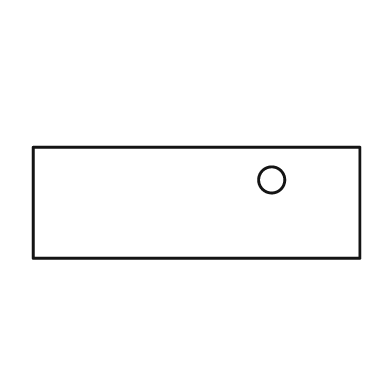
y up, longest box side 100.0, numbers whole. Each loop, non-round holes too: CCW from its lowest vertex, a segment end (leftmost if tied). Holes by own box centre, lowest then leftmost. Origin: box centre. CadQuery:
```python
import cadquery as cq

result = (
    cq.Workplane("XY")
    .moveTo(-50.0, -17.0)
    .lineTo(50.0, -17.0)
    .lineTo(50.0, 17.0)
    .lineTo(-50.0, 17.0)
    .close()
    .moveTo(23.0, 7.0)
    .circle(4.0)
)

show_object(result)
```